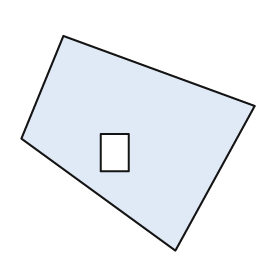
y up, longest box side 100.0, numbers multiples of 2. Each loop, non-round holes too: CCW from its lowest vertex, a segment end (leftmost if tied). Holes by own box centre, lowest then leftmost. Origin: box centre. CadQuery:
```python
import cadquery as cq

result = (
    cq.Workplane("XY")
    .moveTo(16.0, -46.0)
    .lineTo(50.0, 16.0)
    .lineTo(-32.0, 46.0)
    .lineTo(-50.0, 2.0)
    .close()
    .moveTo(-16.0, -12.0)
    .lineTo(-4.0, -12.0)
    .lineTo(-4.0, 4.0)
    .lineTo(-16.0, 4.0)
    .close()
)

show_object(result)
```